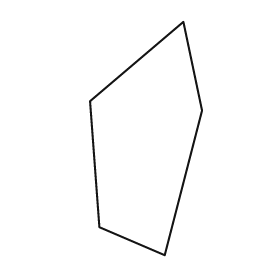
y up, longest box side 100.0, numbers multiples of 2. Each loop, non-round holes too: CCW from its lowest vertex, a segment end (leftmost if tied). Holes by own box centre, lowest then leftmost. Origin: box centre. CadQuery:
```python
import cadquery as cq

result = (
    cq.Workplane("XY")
    .moveTo(8.0, -50.0)
    .lineTo(24.0, 12.0)
    .lineTo(16.0, 50.0)
    .lineTo(-24.0, 16.0)
    .lineTo(-20.0, -38.0)
    .close()
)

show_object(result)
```